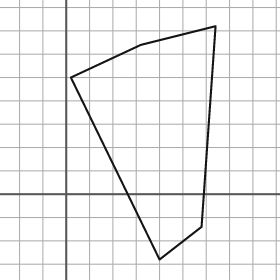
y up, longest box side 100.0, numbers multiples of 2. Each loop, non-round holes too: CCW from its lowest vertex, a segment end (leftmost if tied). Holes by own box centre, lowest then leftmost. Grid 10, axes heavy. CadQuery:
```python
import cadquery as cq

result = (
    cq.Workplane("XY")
    .moveTo(40.0, -28.0)
    .lineTo(58.0, -14.0)
    .lineTo(64.0, 72.0)
    .lineTo(32.0, 64.0)
    .lineTo(2.0, 50.0)
    .close()
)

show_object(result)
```